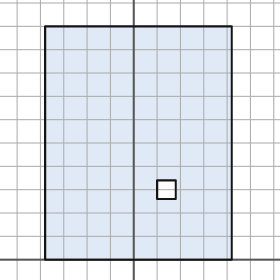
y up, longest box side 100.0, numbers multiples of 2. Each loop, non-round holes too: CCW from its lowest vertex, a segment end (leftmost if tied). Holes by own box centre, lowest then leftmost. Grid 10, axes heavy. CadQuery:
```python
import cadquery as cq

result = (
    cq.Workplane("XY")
    .moveTo(-38.0, 0.0)
    .lineTo(42.0, 0.0)
    .lineTo(42.0, 100.0)
    .lineTo(-38.0, 100.0)
    .close()
    .moveTo(10.0, 26.0)
    .lineTo(18.0, 26.0)
    .lineTo(18.0, 34.0)
    .lineTo(10.0, 34.0)
    .close()
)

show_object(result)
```